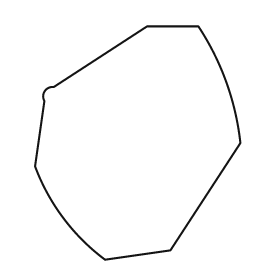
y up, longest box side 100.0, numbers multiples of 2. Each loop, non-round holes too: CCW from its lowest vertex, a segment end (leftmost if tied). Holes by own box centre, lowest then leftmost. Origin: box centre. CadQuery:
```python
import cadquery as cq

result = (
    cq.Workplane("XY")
    .moveTo(-14.0, -50.0)
    .lineTo(14.0, -46.0)
    .lineTo(44.0, 0.0)
    .threePointArc((38.0, 26.0), (26.0, 50.0))
    .lineTo(4.0, 50.0)
    .lineTo(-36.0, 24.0)
    .threePointArc((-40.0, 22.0), (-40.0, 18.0))
    .lineTo(-44.0, -10.0)
    .threePointArc((-32.0, -32.0), (-14.0, -50.0))
    .close()
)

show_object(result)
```